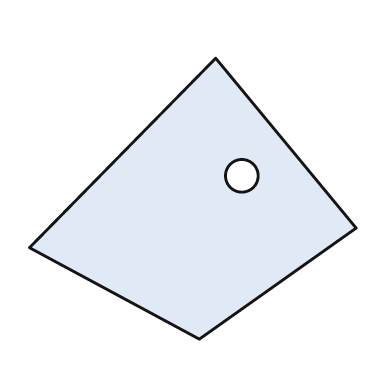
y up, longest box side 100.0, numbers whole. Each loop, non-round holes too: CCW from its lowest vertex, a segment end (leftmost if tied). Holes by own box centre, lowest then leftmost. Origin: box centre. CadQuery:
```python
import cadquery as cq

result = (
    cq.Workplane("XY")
    .moveTo(2.0, -43.0)
    .lineTo(50.0, -9.0)
    .lineTo(7.0, 43.0)
    .lineTo(-50.0, -15.0)
    .close()
    .moveTo(15.0, 7.0)
    .circle(5.0)
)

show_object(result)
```